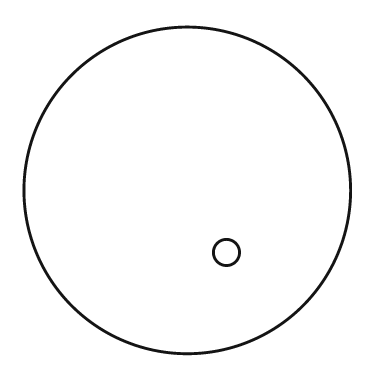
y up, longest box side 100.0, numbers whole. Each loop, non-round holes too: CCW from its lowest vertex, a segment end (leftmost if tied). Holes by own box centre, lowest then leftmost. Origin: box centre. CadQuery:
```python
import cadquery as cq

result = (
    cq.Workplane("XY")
    .moveTo(0.0, 0.0)
    .circle(50.0)
    .moveTo(12.0, -19.0)
    .circle(4.0)
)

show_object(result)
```